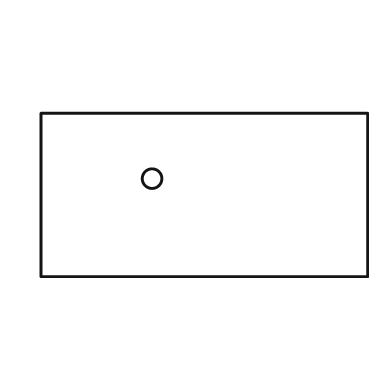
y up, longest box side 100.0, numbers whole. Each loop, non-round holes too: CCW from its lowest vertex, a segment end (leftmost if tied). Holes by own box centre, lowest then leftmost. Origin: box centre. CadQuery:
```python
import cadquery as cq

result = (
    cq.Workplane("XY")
    .moveTo(-50.0, -25.0)
    .lineTo(50.0, -25.0)
    .lineTo(50.0, 25.0)
    .lineTo(-50.0, 25.0)
    .close()
    .moveTo(-16.0, 5.0)
    .circle(3.0)
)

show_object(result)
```